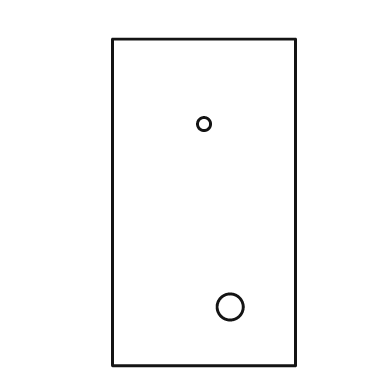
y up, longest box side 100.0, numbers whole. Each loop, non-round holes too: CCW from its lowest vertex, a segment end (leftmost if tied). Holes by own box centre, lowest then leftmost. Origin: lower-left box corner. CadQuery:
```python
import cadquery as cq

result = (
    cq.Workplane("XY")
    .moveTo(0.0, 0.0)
    .lineTo(56.0, 0.0)
    .lineTo(56.0, 100.0)
    .lineTo(0.0, 100.0)
    .close()
    .moveTo(36.0, 18.0)
    .circle(4.0)
    .moveTo(28.0, 74.0)
    .circle(2.0)
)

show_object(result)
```